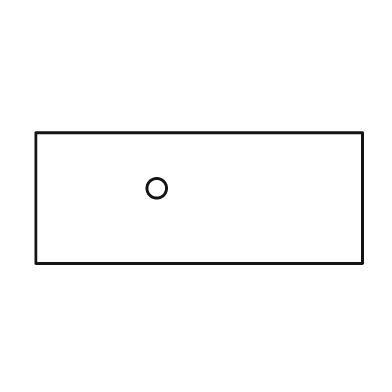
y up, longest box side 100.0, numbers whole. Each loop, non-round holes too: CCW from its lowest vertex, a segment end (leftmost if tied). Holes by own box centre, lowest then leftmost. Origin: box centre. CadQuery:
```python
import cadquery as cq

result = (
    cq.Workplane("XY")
    .moveTo(-50.0, -20.0)
    .lineTo(50.0, -20.0)
    .lineTo(50.0, 20.0)
    .lineTo(-50.0, 20.0)
    .close()
    .moveTo(-13.0, 3.0)
    .circle(3.0)
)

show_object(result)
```